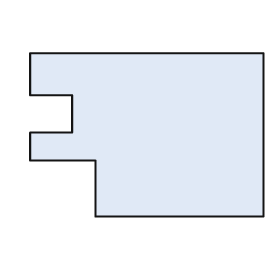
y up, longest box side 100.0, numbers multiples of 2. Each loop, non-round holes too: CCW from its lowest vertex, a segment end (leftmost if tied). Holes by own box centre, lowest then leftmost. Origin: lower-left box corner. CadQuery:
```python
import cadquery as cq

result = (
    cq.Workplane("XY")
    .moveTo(28.0, 0.0)
    .lineTo(100.0, 0.0)
    .lineTo(100.0, 70.0)
    .lineTo(0.0, 70.0)
    .lineTo(0.0, 52.0)
    .lineTo(18.0, 52.0)
    .lineTo(18.0, 36.0)
    .lineTo(0.0, 36.0)
    .lineTo(0.0, 24.0)
    .lineTo(28.0, 24.0)
    .close()
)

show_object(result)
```